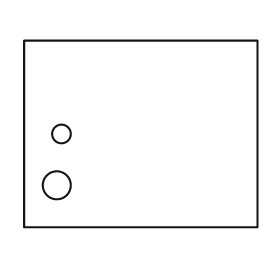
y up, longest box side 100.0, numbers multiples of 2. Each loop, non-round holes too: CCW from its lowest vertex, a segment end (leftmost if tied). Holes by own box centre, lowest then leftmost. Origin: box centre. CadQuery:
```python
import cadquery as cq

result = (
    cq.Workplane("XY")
    .moveTo(-50.0, -40.0)
    .lineTo(50.0, -40.0)
    .lineTo(50.0, 40.0)
    .lineTo(-50.0, 40.0)
    .close()
    .moveTo(-36.0, -22.0)
    .circle(6.0)
    .moveTo(-34.0, 0.0)
    .circle(4.0)
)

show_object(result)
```